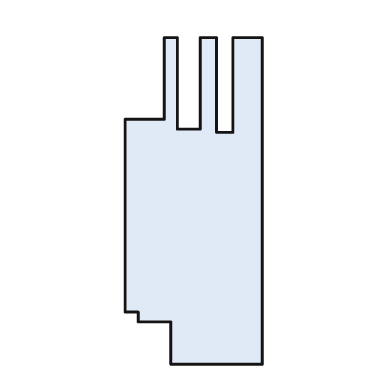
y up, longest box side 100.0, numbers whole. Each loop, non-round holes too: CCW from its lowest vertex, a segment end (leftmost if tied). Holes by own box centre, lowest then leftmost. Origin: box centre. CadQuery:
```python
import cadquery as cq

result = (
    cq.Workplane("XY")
    .moveTo(-7.0, -50.0)
    .lineTo(21.0, -50.0)
    .lineTo(21.0, 50.0)
    .lineTo(12.0, 50.0)
    .lineTo(12.0, 21.0)
    .lineTo(7.0, 21.0)
    .lineTo(7.0, 50.0)
    .lineTo(2.0, 50.0)
    .lineTo(2.0, 22.0)
    .lineTo(-5.0, 22.0)
    .lineTo(-5.0, 50.0)
    .lineTo(-9.0, 50.0)
    .lineTo(-9.0, 25.0)
    .lineTo(-21.0, 25.0)
    .lineTo(-21.0, -34.0)
    .lineTo(-17.0, -34.0)
    .lineTo(-17.0, -37.0)
    .lineTo(-7.0, -37.0)
    .close()
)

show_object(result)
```